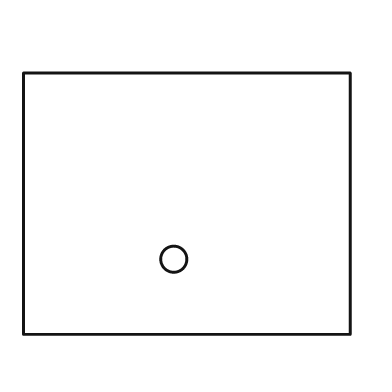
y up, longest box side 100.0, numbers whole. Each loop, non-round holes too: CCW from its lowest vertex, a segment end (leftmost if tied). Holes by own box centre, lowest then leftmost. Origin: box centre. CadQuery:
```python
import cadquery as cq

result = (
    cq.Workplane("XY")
    .moveTo(-50.0, -40.0)
    .lineTo(50.0, -40.0)
    .lineTo(50.0, 40.0)
    .lineTo(-50.0, 40.0)
    .close()
    .moveTo(-4.0, -17.0)
    .circle(4.0)
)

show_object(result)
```